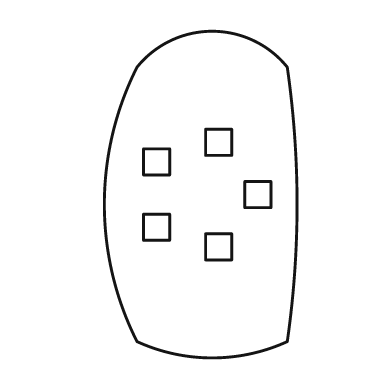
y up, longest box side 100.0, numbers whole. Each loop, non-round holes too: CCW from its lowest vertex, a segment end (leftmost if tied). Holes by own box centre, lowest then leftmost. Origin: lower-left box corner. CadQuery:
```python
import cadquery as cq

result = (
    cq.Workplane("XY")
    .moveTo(10.0, 5.0)
    .threePointArc((33.0, 0.0), (56.0, 5.0))
    .threePointArc((59.0, 47.0), (56.0, 89.0))
    .threePointArc((33.0, 100.0), (10.0, 89.0))
    .threePointArc((0.0, 47.0), (10.0, 5.0))
    .close()
    .moveTo(31.0, 30.0)
    .lineTo(39.0, 30.0)
    .lineTo(39.0, 38.0)
    .lineTo(31.0, 38.0)
    .close()
    .moveTo(12.0, 36.0)
    .lineTo(20.0, 36.0)
    .lineTo(20.0, 44.0)
    .lineTo(12.0, 44.0)
    .close()
    .moveTo(43.0, 46.0)
    .lineTo(51.0, 46.0)
    .lineTo(51.0, 54.0)
    .lineTo(43.0, 54.0)
    .close()
    .moveTo(12.0, 56.0)
    .lineTo(20.0, 56.0)
    .lineTo(20.0, 64.0)
    .lineTo(12.0, 64.0)
    .close()
    .moveTo(31.0, 62.0)
    .lineTo(39.0, 62.0)
    .lineTo(39.0, 70.0)
    .lineTo(31.0, 70.0)
    .close()
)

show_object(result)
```